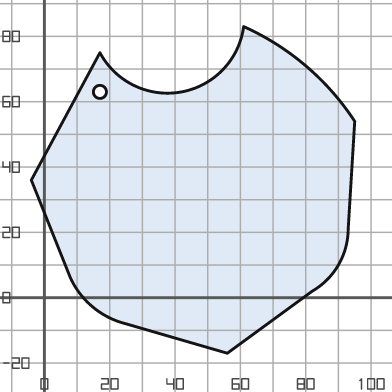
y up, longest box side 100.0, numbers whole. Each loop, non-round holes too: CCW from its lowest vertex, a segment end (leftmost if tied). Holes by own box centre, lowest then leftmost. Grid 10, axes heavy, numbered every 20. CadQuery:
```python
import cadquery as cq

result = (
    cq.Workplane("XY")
    .moveTo(56.0, -17.0)
    .lineTo(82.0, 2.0)
    .threePointArc((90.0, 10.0), (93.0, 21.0))
    .lineTo(95.0, 54.0)
    .threePointArc((80.0, 71.0), (61.0, 83.0))
    .threePointArc((42.0, 63.0), (17.0, 75.0))
    .lineTo(-4.0, 36.0)
    .lineTo(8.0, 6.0)
    .threePointArc((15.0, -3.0), (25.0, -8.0))
    .close()
    .moveTo(17.0, 63.0)
    .circle(2.0)
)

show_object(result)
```